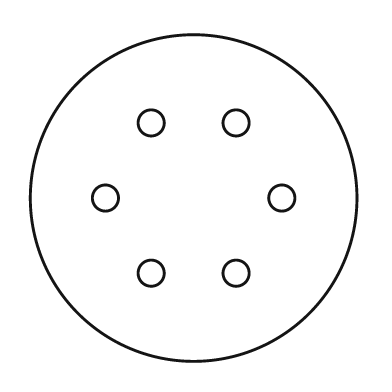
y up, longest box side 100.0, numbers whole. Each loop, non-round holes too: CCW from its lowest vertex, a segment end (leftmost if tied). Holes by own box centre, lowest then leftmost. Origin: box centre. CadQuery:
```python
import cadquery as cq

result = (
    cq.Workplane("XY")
    .moveTo(0.0, 0.0)
    .circle(50.0)
    .moveTo(-13.0, -23.0)
    .circle(4.0)
    .moveTo(13.0, -23.0)
    .circle(4.0)
    .moveTo(-27.0, 0.0)
    .circle(4.0)
    .moveTo(27.0, 0.0)
    .circle(4.0)
    .moveTo(-13.0, 23.0)
    .circle(4.0)
    .moveTo(13.0, 23.0)
    .circle(4.0)
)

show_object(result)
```